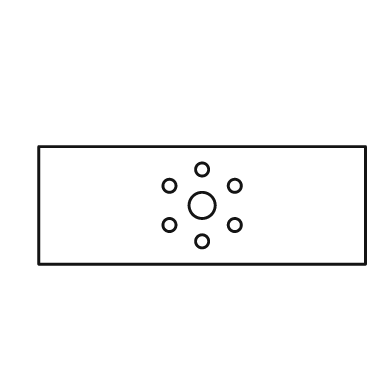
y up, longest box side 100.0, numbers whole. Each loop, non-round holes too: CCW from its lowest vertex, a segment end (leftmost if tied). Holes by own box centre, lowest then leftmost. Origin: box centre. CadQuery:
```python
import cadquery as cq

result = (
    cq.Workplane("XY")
    .moveTo(-50.0, -18.0)
    .lineTo(50.0, -18.0)
    .lineTo(50.0, 18.0)
    .lineTo(-50.0, 18.0)
    .close()
    .moveTo(0.0, -11.0)
    .circle(2.0)
    .moveTo(-10.0, -6.0)
    .circle(2.0)
    .moveTo(10.0, -6.0)
    .circle(2.0)
    .moveTo(0.0, 0.0)
    .circle(4.0)
    .moveTo(-10.0, 6.0)
    .circle(2.0)
    .moveTo(10.0, 6.0)
    .circle(2.0)
    .moveTo(0.0, 11.0)
    .circle(2.0)
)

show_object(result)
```